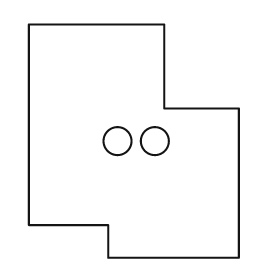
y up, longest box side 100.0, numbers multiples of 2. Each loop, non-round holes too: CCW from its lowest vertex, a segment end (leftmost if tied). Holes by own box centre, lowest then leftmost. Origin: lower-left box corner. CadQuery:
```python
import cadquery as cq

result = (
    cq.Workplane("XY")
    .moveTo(34.0, 0.0)
    .lineTo(90.0, 0.0)
    .lineTo(90.0, 64.0)
    .lineTo(58.0, 64.0)
    .lineTo(58.0, 100.0)
    .lineTo(0.0, 100.0)
    .lineTo(0.0, 14.0)
    .lineTo(34.0, 14.0)
    .close()
    .moveTo(38.0, 50.0)
    .circle(6.0)
    .moveTo(54.0, 50.0)
    .circle(6.0)
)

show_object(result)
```